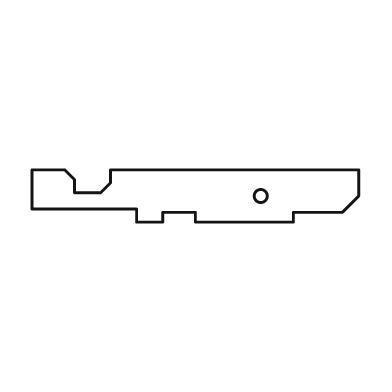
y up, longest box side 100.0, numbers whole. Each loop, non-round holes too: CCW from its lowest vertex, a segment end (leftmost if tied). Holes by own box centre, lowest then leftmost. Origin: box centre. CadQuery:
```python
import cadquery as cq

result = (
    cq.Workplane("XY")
    .moveTo(-18.0, -8.0)
    .lineTo(-10.0, -8.0)
    .lineTo(-10.0, -5.0)
    .lineTo(0.0, -5.0)
    .lineTo(0.0, -8.0)
    .lineTo(30.0, -8.0)
    .lineTo(30.0, -5.0)
    .lineTo(45.0, -5.0)
    .lineTo(50.0, 0.0)
    .lineTo(50.0, 8.0)
    .lineTo(-26.0, 8.0)
    .lineTo(-26.0, 4.0)
    .lineTo(-29.0, 1.0)
    .lineTo(-37.0, 1.0)
    .lineTo(-37.0, 5.0)
    .lineTo(-40.0, 8.0)
    .lineTo(-50.0, 8.0)
    .lineTo(-50.0, -4.0)
    .lineTo(-18.0, -4.0)
    .close()
    .moveTo(20.0, 0.0)
    .circle(2.0)
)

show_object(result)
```